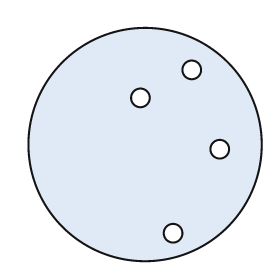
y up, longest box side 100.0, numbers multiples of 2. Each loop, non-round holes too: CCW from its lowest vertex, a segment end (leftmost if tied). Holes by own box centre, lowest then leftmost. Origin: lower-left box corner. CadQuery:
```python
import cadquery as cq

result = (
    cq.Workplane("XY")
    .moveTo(50.0, 50.0)
    .circle(50.0)
    .moveTo(62.0, 12.0)
    .circle(4.0)
    .moveTo(82.0, 48.0)
    .circle(4.0)
    .moveTo(48.0, 70.0)
    .circle(4.0)
    .moveTo(70.0, 82.0)
    .circle(4.0)
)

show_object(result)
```